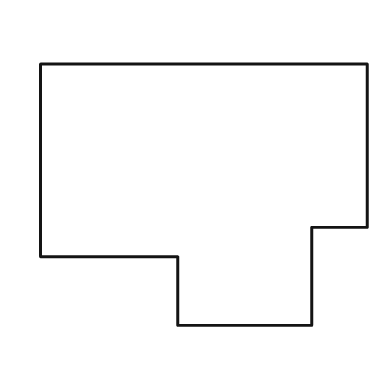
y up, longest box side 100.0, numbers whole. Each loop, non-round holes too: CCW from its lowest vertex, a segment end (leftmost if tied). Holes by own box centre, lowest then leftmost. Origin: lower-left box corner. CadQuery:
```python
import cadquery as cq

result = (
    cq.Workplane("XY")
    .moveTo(42.0, 0.0)
    .lineTo(83.0, 0.0)
    .lineTo(83.0, 30.0)
    .lineTo(100.0, 30.0)
    .lineTo(100.0, 80.0)
    .lineTo(0.0, 80.0)
    .lineTo(0.0, 21.0)
    .lineTo(42.0, 21.0)
    .close()
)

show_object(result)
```